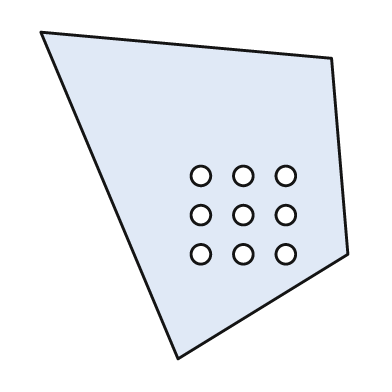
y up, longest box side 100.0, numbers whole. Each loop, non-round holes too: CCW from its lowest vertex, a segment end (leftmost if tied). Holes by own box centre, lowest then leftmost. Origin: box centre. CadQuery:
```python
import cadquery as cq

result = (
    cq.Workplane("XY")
    .moveTo(-5.0, -50.0)
    .lineTo(47.0, -18.0)
    .lineTo(42.0, 42.0)
    .lineTo(-47.0, 50.0)
    .close()
    .moveTo(2.0, -18.0)
    .circle(3.0)
    .moveTo(15.0, -18.0)
    .circle(3.0)
    .moveTo(28.0, -18.0)
    .circle(3.0)
    .moveTo(2.0, -6.0)
    .circle(3.0)
    .moveTo(15.0, -6.0)
    .circle(3.0)
    .moveTo(28.0, -6.0)
    .circle(3.0)
    .moveTo(2.0, 6.0)
    .circle(3.0)
    .moveTo(15.0, 6.0)
    .circle(3.0)
    .moveTo(28.0, 6.0)
    .circle(3.0)
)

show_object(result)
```